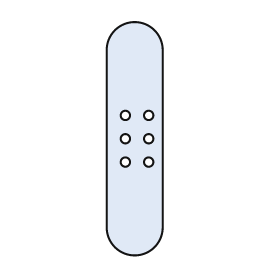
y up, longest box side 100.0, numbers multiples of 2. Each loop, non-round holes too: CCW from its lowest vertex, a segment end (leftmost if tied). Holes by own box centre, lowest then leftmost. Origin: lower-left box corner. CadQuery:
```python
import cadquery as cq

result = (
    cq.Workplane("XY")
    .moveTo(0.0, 12.0)
    .threePointArc((12.0, 0.0), (24.0, 12.0))
    .lineTo(24.0, 88.0)
    .threePointArc((12.0, 100.0), (0.0, 88.0))
    .close()
    .moveTo(8.0, 40.0)
    .circle(2.0)
    .moveTo(18.0, 40.0)
    .circle(2.0)
    .moveTo(8.0, 50.0)
    .circle(2.0)
    .moveTo(18.0, 50.0)
    .circle(2.0)
    .moveTo(8.0, 60.0)
    .circle(2.0)
    .moveTo(18.0, 60.0)
    .circle(2.0)
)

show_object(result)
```